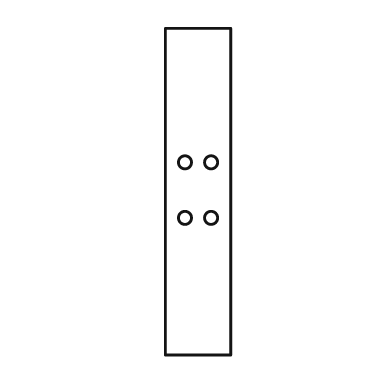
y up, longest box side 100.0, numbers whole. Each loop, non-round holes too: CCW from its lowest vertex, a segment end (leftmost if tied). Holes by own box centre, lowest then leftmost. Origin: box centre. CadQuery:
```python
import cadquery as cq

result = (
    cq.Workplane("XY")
    .moveTo(-10.0, -50.0)
    .lineTo(10.0, -50.0)
    .lineTo(10.0, 50.0)
    .lineTo(-10.0, 50.0)
    .close()
    .moveTo(-4.0, -8.0)
    .circle(2.0)
    .moveTo(4.0, -8.0)
    .circle(2.0)
    .moveTo(-4.0, 9.0)
    .circle(2.0)
    .moveTo(4.0, 9.0)
    .circle(2.0)
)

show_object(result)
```